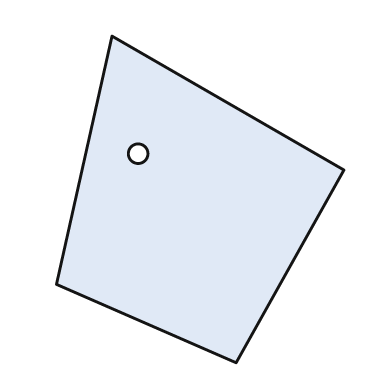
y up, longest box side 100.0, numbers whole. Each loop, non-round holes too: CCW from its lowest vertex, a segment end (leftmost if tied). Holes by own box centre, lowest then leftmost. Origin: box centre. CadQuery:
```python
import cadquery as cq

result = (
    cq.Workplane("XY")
    .moveTo(11.0, -50.0)
    .lineTo(44.0, 9.0)
    .lineTo(-27.0, 50.0)
    .lineTo(-44.0, -26.0)
    .close()
    .moveTo(-19.0, 14.0)
    .circle(3.0)
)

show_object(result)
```